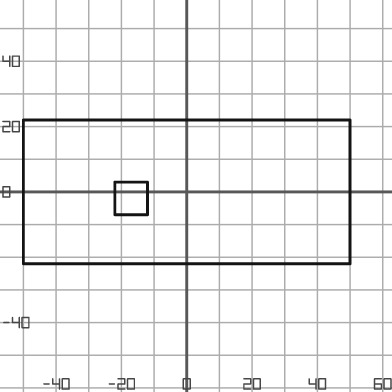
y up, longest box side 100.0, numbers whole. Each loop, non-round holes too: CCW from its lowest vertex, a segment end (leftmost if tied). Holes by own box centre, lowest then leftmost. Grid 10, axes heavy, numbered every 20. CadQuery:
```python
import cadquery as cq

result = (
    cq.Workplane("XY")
    .moveTo(-50.0, -22.0)
    .lineTo(50.0, -22.0)
    .lineTo(50.0, 22.0)
    .lineTo(-50.0, 22.0)
    .close()
    .moveTo(-22.0, -7.0)
    .lineTo(-12.0, -7.0)
    .lineTo(-12.0, 3.0)
    .lineTo(-22.0, 3.0)
    .close()
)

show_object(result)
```